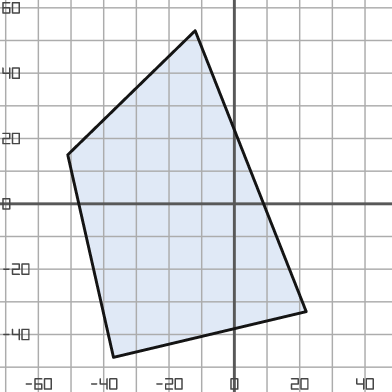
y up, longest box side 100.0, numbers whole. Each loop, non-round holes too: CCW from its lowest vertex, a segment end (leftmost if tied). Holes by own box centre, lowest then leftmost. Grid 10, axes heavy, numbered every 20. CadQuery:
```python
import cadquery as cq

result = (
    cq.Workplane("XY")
    .moveTo(-37.0, -47.0)
    .lineTo(22.0, -33.0)
    .lineTo(-12.0, 53.0)
    .lineTo(-51.0, 15.0)
    .close()
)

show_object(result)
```